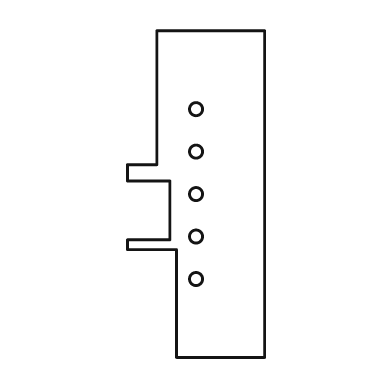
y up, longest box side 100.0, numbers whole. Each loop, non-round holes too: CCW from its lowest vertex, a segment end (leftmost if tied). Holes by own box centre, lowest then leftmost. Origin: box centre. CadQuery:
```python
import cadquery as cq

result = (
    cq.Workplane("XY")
    .moveTo(-6.0, -50.0)
    .lineTo(21.0, -50.0)
    .lineTo(21.0, 50.0)
    .lineTo(-12.0, 50.0)
    .lineTo(-12.0, 9.0)
    .lineTo(-21.0, 9.0)
    .lineTo(-21.0, 4.0)
    .lineTo(-8.0, 4.0)
    .lineTo(-8.0, -14.0)
    .lineTo(-21.0, -14.0)
    .lineTo(-21.0, -17.0)
    .lineTo(-6.0, -17.0)
    .close()
    .moveTo(0.0, -26.0)
    .circle(2.0)
    .moveTo(0.0, -13.0)
    .circle(2.0)
    .moveTo(0.0, 0.0)
    .circle(2.0)
    .moveTo(0.0, 13.0)
    .circle(2.0)
    .moveTo(0.0, 26.0)
    .circle(2.0)
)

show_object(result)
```